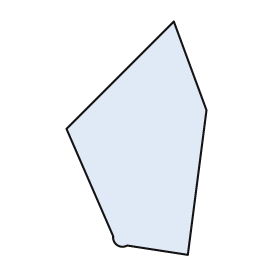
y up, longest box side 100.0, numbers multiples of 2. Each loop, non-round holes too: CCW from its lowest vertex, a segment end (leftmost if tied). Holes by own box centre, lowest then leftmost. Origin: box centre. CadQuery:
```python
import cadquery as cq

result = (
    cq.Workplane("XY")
    .moveTo(22.0, -50.0)
    .lineTo(30.0, 12.0)
    .lineTo(16.0, 50.0)
    .lineTo(-30.0, 4.0)
    .lineTo(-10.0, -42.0)
    .threePointArc((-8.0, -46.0), (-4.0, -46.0))
    .close()
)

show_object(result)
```